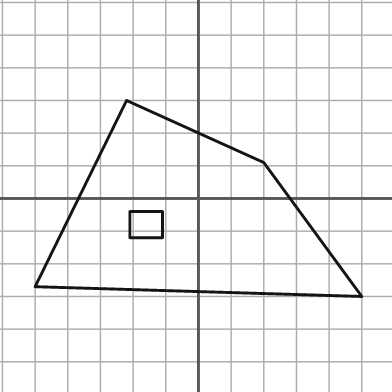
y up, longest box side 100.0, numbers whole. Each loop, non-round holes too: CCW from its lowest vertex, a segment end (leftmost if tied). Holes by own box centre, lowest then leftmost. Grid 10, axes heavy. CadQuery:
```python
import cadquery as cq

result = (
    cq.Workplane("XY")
    .moveTo(50.0, -30.0)
    .lineTo(20.0, 11.0)
    .lineTo(-22.0, 30.0)
    .lineTo(-50.0, -27.0)
    .close()
    .moveTo(-21.0, -12.0)
    .lineTo(-11.0, -12.0)
    .lineTo(-11.0, -4.0)
    .lineTo(-21.0, -4.0)
    .close()
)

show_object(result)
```